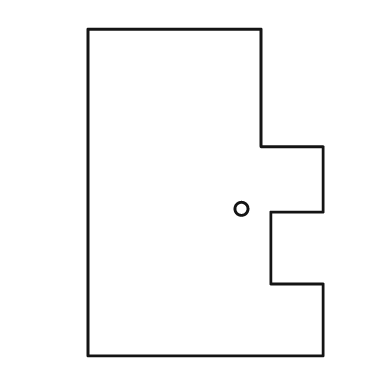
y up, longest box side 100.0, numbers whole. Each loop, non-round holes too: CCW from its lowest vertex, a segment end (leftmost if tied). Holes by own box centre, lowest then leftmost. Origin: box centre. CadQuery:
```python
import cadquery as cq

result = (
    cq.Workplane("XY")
    .moveTo(-36.0, -50.0)
    .lineTo(36.0, -50.0)
    .lineTo(36.0, -28.0)
    .lineTo(20.0, -28.0)
    .lineTo(20.0, -6.0)
    .lineTo(36.0, -6.0)
    .lineTo(36.0, 14.0)
    .lineTo(17.0, 14.0)
    .lineTo(17.0, 50.0)
    .lineTo(-36.0, 50.0)
    .close()
    .moveTo(11.0, -5.0)
    .circle(2.0)
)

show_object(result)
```